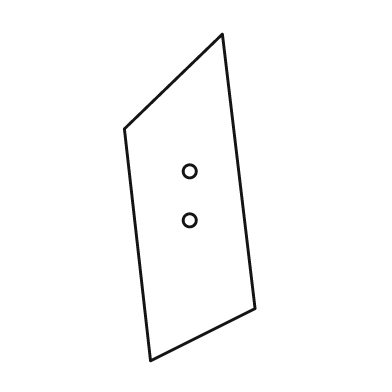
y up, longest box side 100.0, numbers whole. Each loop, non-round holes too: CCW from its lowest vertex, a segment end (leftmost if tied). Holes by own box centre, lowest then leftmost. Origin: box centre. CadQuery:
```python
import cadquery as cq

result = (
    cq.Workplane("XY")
    .moveTo(-12.0, -50.0)
    .lineTo(20.0, -34.0)
    .lineTo(10.0, 50.0)
    .lineTo(-20.0, 21.0)
    .close()
    .moveTo(0.0, -7.0)
    .circle(2.0)
    .moveTo(0.0, 8.0)
    .circle(2.0)
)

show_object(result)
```